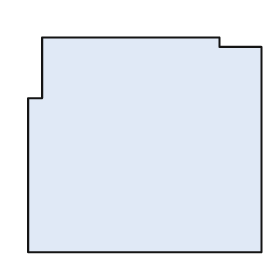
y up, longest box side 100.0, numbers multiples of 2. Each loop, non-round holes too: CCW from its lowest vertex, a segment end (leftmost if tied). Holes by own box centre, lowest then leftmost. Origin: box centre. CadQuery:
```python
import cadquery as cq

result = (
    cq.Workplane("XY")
    .moveTo(-50.0, -46.0)
    .lineTo(50.0, -46.0)
    .lineTo(50.0, 42.0)
    .lineTo(32.0, 42.0)
    .lineTo(32.0, 46.0)
    .lineTo(-44.0, 46.0)
    .lineTo(-44.0, 20.0)
    .lineTo(-50.0, 20.0)
    .close()
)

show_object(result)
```